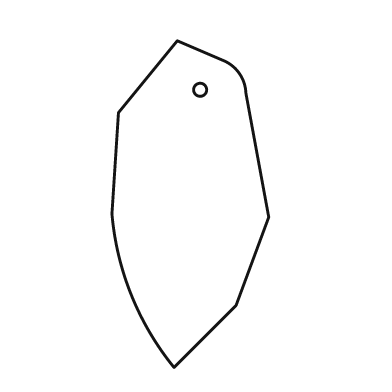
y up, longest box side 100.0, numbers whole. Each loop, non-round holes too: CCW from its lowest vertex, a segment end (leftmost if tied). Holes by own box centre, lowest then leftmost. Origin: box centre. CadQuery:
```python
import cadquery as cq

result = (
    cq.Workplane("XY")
    .moveTo(-5.0, -50.0)
    .lineTo(14.0, -31.0)
    .lineTo(24.0, -4.0)
    .lineTo(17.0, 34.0)
    .threePointArc((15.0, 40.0), (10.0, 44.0))
    .lineTo(-4.0, 50.0)
    .lineTo(-22.0, 28.0)
    .lineTo(-24.0, -3.0)
    .threePointArc((-18.0, -28.0), (-5.0, -50.0))
    .close()
    .moveTo(3.0, 35.0)
    .circle(2.0)
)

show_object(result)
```